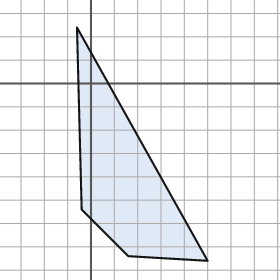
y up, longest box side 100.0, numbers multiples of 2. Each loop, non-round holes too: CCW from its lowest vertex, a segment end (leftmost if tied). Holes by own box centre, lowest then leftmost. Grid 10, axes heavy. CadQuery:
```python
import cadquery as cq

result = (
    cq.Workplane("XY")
    .moveTo(50.0, -76.0)
    .lineTo(-6.0, 24.0)
    .lineTo(-4.0, -54.0)
    .lineTo(16.0, -74.0)
    .close()
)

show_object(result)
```